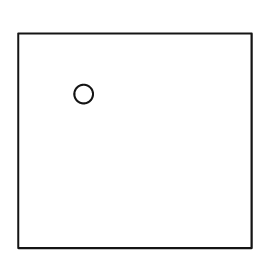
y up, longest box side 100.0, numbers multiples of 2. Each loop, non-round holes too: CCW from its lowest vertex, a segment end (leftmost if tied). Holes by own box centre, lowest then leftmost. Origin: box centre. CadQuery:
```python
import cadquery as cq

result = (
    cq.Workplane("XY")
    .moveTo(-50.0, -46.0)
    .lineTo(50.0, -46.0)
    .lineTo(50.0, 46.0)
    .lineTo(-50.0, 46.0)
    .close()
    .moveTo(-22.0, 20.0)
    .circle(4.0)
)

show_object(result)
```